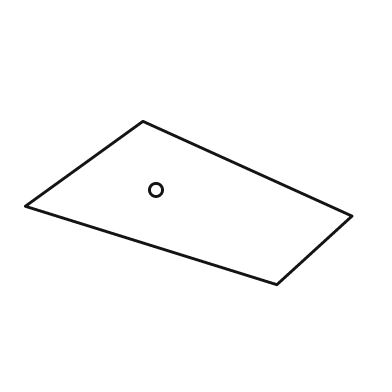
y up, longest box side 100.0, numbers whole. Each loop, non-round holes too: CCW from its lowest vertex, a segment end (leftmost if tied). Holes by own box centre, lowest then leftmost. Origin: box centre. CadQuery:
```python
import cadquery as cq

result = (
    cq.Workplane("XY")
    .moveTo(27.0, -25.0)
    .lineTo(50.0, -4.0)
    .lineTo(-14.0, 25.0)
    .lineTo(-50.0, -1.0)
    .close()
    .moveTo(-10.0, 4.0)
    .circle(2.0)
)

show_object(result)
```